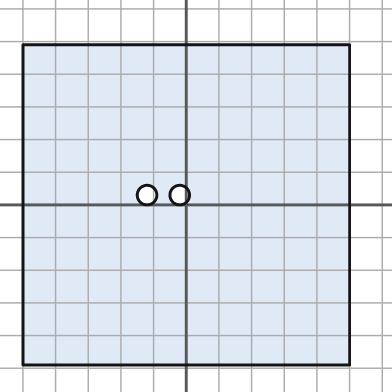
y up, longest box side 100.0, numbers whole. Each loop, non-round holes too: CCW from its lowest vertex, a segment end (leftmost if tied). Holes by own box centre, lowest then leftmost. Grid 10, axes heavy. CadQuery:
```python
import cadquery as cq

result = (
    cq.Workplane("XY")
    .moveTo(-50.0, -49.0)
    .lineTo(50.0, -49.0)
    .lineTo(50.0, 49.0)
    .lineTo(-50.0, 49.0)
    .close()
    .moveTo(-12.0, 3.0)
    .circle(3.0)
    .moveTo(-2.0, 3.0)
    .circle(3.0)
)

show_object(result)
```